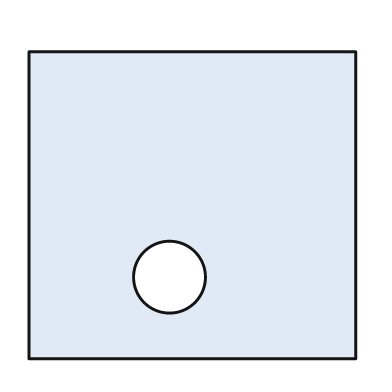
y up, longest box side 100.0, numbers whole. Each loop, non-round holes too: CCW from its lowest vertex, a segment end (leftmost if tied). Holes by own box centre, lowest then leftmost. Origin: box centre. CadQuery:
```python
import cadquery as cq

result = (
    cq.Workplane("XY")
    .moveTo(-50.0, -47.0)
    .lineTo(50.0, -47.0)
    .lineTo(50.0, 47.0)
    .lineTo(-50.0, 47.0)
    .close()
    .moveTo(-7.0, -22.0)
    .circle(11.0)
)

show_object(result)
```